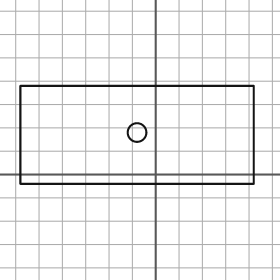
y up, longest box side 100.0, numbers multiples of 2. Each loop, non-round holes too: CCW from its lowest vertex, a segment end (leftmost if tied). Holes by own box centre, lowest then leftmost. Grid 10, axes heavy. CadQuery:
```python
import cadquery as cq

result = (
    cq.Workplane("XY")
    .moveTo(-58.0, -4.0)
    .lineTo(42.0, -4.0)
    .lineTo(42.0, 38.0)
    .lineTo(-58.0, 38.0)
    .close()
    .moveTo(-8.0, 18.0)
    .circle(4.0)
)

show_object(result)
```